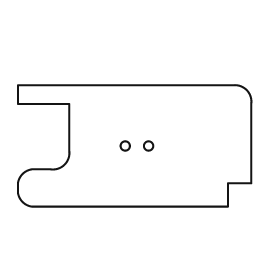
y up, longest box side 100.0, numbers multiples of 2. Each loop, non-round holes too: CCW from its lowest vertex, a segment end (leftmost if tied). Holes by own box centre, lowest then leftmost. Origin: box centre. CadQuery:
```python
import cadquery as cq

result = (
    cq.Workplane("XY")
    .moveTo(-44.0, -26.0)
    .lineTo(40.0, -26.0)
    .lineTo(40.0, -16.0)
    .lineTo(50.0, -16.0)
    .lineTo(50.0, 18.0)
    .threePointArc((48.0, 24.0), (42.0, 26.0))
    .lineTo(-50.0, 26.0)
    .lineTo(-50.0, 18.0)
    .lineTo(-28.0, 18.0)
    .lineTo(-28.0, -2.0)
    .threePointArc((-30.0, -8.0), (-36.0, -10.0))
    .lineTo(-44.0, -10.0)
    .threePointArc((-48.0, -12.0), (-50.0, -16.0))
    .lineTo(-50.0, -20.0)
    .threePointArc((-48.0, -24.0), (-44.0, -26.0))
    .close()
    .moveTo(-4.0, 0.0)
    .circle(2.0)
    .moveTo(6.0, 0.0)
    .circle(2.0)
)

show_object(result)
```